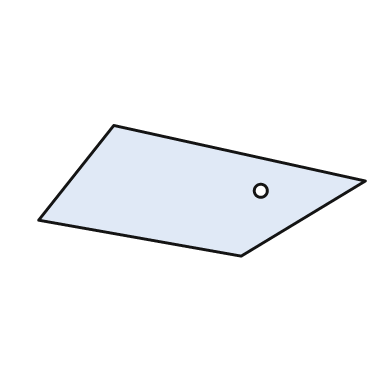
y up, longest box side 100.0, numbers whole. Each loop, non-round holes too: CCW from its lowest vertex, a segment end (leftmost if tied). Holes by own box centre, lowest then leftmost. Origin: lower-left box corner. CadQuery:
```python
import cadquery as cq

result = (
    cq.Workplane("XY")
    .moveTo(62.0, 0.0)
    .lineTo(100.0, 23.0)
    .lineTo(23.0, 40.0)
    .lineTo(0.0, 11.0)
    .close()
    .moveTo(68.0, 20.0)
    .circle(2.0)
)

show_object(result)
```